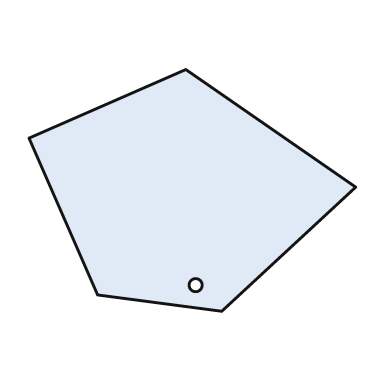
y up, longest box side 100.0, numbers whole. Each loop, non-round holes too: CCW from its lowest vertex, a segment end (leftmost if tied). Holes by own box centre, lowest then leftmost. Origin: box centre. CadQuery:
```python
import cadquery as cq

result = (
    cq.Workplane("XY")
    .moveTo(9.0, -37.0)
    .lineTo(50.0, 1.0)
    .lineTo(-2.0, 37.0)
    .lineTo(-50.0, 16.0)
    .lineTo(-29.0, -32.0)
    .close()
    .moveTo(1.0, -29.0)
    .circle(2.0)
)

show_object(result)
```